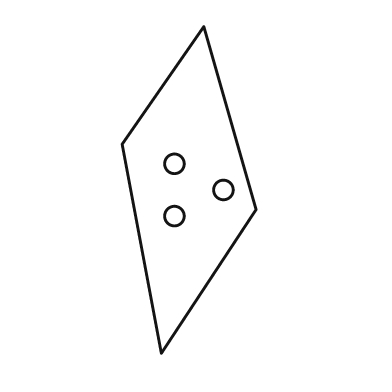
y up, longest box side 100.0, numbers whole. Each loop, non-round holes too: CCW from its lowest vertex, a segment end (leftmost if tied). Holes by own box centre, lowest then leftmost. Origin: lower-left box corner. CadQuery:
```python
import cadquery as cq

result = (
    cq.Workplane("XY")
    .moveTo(12.0, 0.0)
    .lineTo(41.0, 44.0)
    .lineTo(25.0, 100.0)
    .lineTo(0.0, 64.0)
    .close()
    .moveTo(16.0, 42.0)
    .circle(3.0)
    .moveTo(31.0, 50.0)
    .circle(3.0)
    .moveTo(16.0, 58.0)
    .circle(3.0)
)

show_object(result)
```